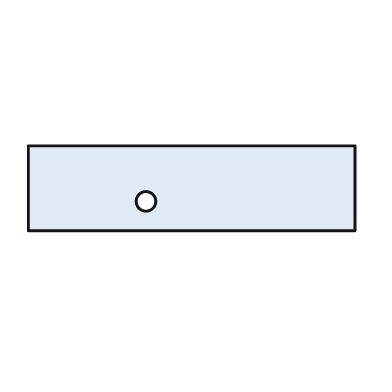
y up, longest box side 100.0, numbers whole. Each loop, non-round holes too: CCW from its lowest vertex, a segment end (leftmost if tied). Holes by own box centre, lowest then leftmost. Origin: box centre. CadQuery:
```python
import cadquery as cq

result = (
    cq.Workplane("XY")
    .moveTo(-50.0, -13.0)
    .lineTo(50.0, -13.0)
    .lineTo(50.0, 13.0)
    .lineTo(-50.0, 13.0)
    .close()
    .moveTo(-14.0, -4.0)
    .circle(3.0)
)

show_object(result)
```